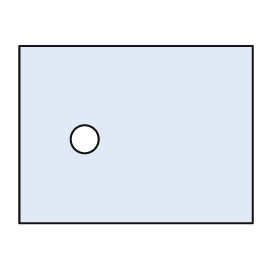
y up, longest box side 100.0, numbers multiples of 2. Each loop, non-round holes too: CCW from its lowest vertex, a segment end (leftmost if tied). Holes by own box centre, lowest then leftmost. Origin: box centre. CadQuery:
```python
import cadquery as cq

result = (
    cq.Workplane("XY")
    .moveTo(-50.0, -38.0)
    .lineTo(50.0, -38.0)
    .lineTo(50.0, 38.0)
    .lineTo(-50.0, 38.0)
    .close()
    .moveTo(-22.0, -2.0)
    .circle(6.0)
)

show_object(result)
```